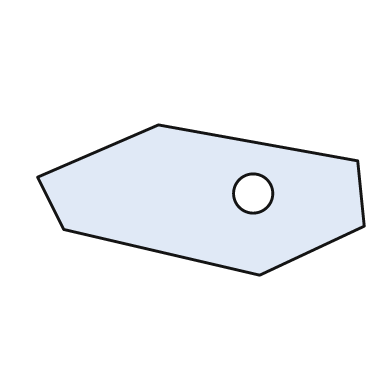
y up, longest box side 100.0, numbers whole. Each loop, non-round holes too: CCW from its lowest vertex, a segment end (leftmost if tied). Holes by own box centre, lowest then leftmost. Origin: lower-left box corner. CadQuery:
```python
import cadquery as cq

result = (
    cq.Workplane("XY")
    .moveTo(68.0, 0.0)
    .lineTo(100.0, 15.0)
    .lineTo(98.0, 35.0)
    .lineTo(37.0, 46.0)
    .lineTo(0.0, 30.0)
    .lineTo(8.0, 14.0)
    .close()
    .moveTo(66.0, 25.0)
    .circle(6.0)
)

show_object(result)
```